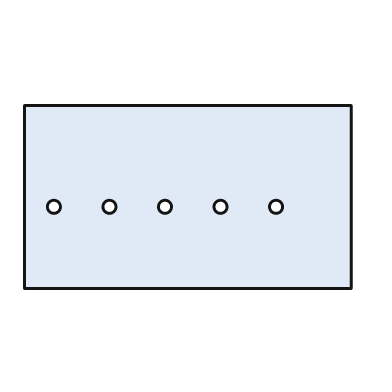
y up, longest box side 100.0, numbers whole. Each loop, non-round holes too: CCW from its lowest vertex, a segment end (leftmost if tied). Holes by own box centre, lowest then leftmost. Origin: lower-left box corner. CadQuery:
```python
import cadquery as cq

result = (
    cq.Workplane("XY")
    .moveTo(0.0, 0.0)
    .lineTo(100.0, 0.0)
    .lineTo(100.0, 56.0)
    .lineTo(0.0, 56.0)
    .close()
    .moveTo(9.0, 25.0)
    .circle(2.0)
    .moveTo(26.0, 25.0)
    .circle(2.0)
    .moveTo(43.0, 25.0)
    .circle(2.0)
    .moveTo(60.0, 25.0)
    .circle(2.0)
    .moveTo(77.0, 25.0)
    .circle(2.0)
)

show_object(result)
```